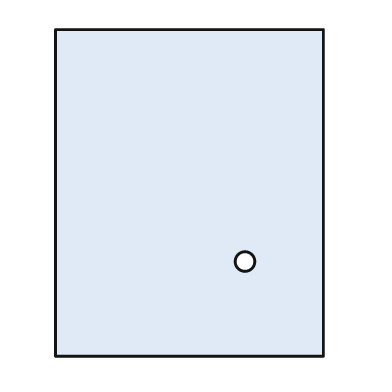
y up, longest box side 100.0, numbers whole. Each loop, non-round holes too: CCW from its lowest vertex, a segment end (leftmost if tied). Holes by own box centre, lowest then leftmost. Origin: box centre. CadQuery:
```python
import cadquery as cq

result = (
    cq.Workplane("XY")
    .moveTo(-41.0, -50.0)
    .lineTo(41.0, -50.0)
    .lineTo(41.0, 50.0)
    .lineTo(-41.0, 50.0)
    .close()
    .moveTo(17.0, -21.0)
    .circle(3.0)
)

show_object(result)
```